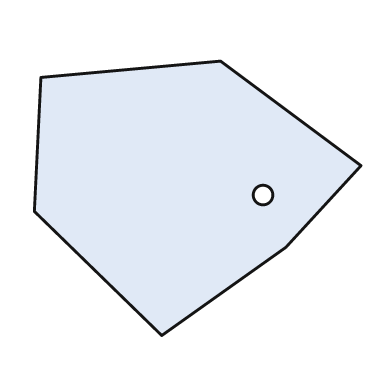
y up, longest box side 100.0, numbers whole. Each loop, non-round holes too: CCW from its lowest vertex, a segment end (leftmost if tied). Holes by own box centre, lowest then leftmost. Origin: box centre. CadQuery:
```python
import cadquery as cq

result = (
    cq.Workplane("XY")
    .moveTo(-11.0, -42.0)
    .lineTo(27.0, -15.0)
    .lineTo(50.0, 10.0)
    .lineTo(7.0, 42.0)
    .lineTo(-48.0, 37.0)
    .lineTo(-50.0, -4.0)
    .close()
    .moveTo(20.0, 1.0)
    .circle(3.0)
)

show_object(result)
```